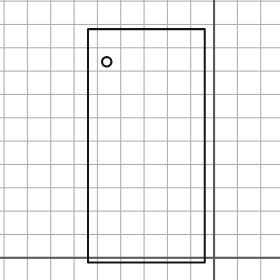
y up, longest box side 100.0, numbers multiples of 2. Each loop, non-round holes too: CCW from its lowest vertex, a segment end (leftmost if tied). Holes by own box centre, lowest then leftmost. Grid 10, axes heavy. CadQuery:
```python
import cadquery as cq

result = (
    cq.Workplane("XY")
    .moveTo(-54.0, -2.0)
    .lineTo(-4.0, -2.0)
    .lineTo(-4.0, 98.0)
    .lineTo(-54.0, 98.0)
    .close()
    .moveTo(-46.0, 84.0)
    .circle(2.0)
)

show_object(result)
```